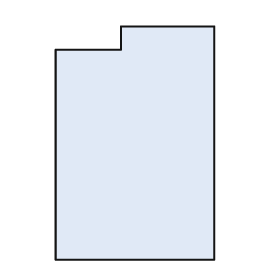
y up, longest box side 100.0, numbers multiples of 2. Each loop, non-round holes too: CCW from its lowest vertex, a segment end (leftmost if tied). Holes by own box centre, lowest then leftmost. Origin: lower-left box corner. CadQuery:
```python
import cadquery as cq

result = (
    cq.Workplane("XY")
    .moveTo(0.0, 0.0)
    .lineTo(68.0, 0.0)
    .lineTo(68.0, 100.0)
    .lineTo(28.0, 100.0)
    .lineTo(28.0, 90.0)
    .lineTo(0.0, 90.0)
    .close()
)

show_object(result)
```